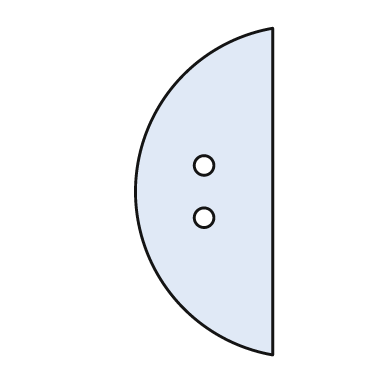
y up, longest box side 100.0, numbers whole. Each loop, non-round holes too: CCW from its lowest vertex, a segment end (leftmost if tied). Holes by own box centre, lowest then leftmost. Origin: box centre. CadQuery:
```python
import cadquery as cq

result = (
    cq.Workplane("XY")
    .moveTo(21.0, -50.0)
    .lineTo(21.0, 50.0)
    .threePointArc((-21.0, 0.0), (21.0, -50.0))
    .close()
    .moveTo(0.0, -8.0)
    .circle(3.0)
    .moveTo(0.0, 8.0)
    .circle(3.0)
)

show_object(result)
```